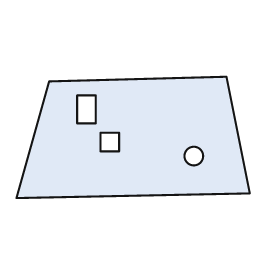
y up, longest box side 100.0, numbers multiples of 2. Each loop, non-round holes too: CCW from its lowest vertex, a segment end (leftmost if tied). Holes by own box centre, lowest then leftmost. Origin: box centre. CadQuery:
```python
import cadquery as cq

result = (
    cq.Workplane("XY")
    .moveTo(-50.0, -26.0)
    .lineTo(50.0, -24.0)
    .lineTo(40.0, 26.0)
    .lineTo(-36.0, 24.0)
    .close()
    .moveTo(26.0, -8.0)
    .circle(4.0)
    .moveTo(-14.0, -6.0)
    .lineTo(-6.0, -6.0)
    .lineTo(-6.0, 2.0)
    .lineTo(-14.0, 2.0)
    .close()
    .moveTo(-24.0, 6.0)
    .lineTo(-16.0, 6.0)
    .lineTo(-16.0, 18.0)
    .lineTo(-24.0, 18.0)
    .close()
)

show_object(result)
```